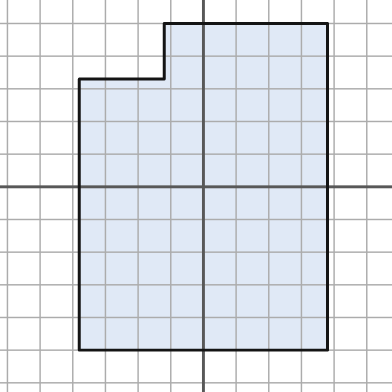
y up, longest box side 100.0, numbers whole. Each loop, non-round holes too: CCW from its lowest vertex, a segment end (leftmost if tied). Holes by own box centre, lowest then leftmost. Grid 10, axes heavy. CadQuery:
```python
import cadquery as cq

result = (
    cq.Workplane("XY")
    .moveTo(-38.0, -50.0)
    .lineTo(38.0, -50.0)
    .lineTo(38.0, 50.0)
    .lineTo(-12.0, 50.0)
    .lineTo(-12.0, 33.0)
    .lineTo(-38.0, 33.0)
    .close()
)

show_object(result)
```